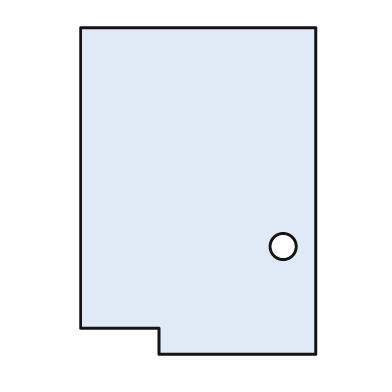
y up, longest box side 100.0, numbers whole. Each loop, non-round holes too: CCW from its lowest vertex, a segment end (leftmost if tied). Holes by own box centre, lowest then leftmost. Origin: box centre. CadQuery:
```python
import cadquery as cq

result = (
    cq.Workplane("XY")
    .moveTo(-12.0, -50.0)
    .lineTo(36.0, -50.0)
    .lineTo(36.0, 50.0)
    .lineTo(-36.0, 50.0)
    .lineTo(-36.0, -42.0)
    .lineTo(-12.0, -42.0)
    .close()
    .moveTo(26.0, -17.0)
    .circle(4.0)
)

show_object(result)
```